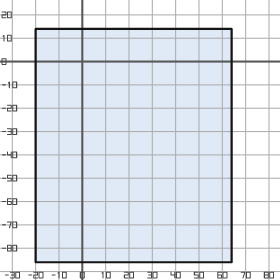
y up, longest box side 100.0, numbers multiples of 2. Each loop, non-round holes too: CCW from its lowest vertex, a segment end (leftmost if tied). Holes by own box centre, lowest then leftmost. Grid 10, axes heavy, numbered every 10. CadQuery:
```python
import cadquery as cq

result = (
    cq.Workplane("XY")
    .moveTo(-20.0, -86.0)
    .lineTo(64.0, -86.0)
    .lineTo(64.0, 14.0)
    .lineTo(-20.0, 14.0)
    .close()
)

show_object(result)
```